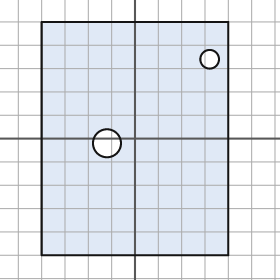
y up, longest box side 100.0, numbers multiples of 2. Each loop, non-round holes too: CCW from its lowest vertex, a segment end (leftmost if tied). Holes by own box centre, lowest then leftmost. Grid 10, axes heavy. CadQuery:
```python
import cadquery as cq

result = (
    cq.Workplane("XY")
    .moveTo(-40.0, -50.0)
    .lineTo(40.0, -50.0)
    .lineTo(40.0, 50.0)
    .lineTo(-40.0, 50.0)
    .close()
    .moveTo(-12.0, -2.0)
    .circle(6.0)
    .moveTo(32.0, 34.0)
    .circle(4.0)
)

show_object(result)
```